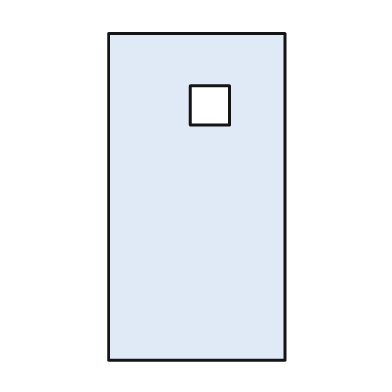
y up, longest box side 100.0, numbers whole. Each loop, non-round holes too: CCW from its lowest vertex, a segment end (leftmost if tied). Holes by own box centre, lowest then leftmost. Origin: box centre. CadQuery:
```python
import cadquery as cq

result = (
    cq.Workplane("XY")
    .moveTo(-27.0, -50.0)
    .lineTo(27.0, -50.0)
    .lineTo(27.0, 50.0)
    .lineTo(-27.0, 50.0)
    .close()
    .moveTo(-2.0, 22.0)
    .lineTo(10.0, 22.0)
    .lineTo(10.0, 34.0)
    .lineTo(-2.0, 34.0)
    .close()
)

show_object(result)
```